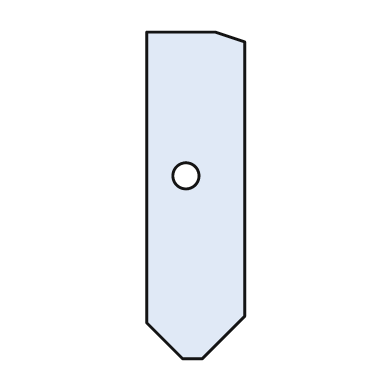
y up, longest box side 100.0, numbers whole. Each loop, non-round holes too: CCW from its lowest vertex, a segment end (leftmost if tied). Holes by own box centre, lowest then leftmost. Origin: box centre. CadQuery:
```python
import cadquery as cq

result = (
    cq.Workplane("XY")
    .moveTo(-4.0, -50.0)
    .lineTo(2.0, -50.0)
    .lineTo(15.0, -37.0)
    .lineTo(15.0, 47.0)
    .lineTo(6.0, 50.0)
    .lineTo(-15.0, 50.0)
    .lineTo(-15.0, -39.0)
    .close()
    .moveTo(-3.0, 6.0)
    .circle(4.0)
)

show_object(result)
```